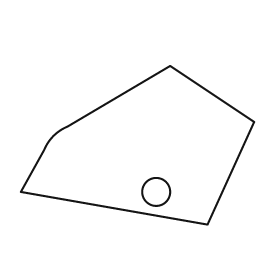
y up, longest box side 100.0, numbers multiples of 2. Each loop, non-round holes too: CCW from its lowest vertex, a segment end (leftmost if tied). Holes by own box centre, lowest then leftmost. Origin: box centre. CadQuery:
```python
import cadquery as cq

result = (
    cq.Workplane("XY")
    .moveTo(30.0, -34.0)
    .lineTo(50.0, 10.0)
    .lineTo(14.0, 34.0)
    .lineTo(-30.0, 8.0)
    .threePointArc((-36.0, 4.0), (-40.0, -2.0))
    .lineTo(-50.0, -20.0)
    .close()
    .moveTo(8.0, -20.0)
    .circle(6.0)
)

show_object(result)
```